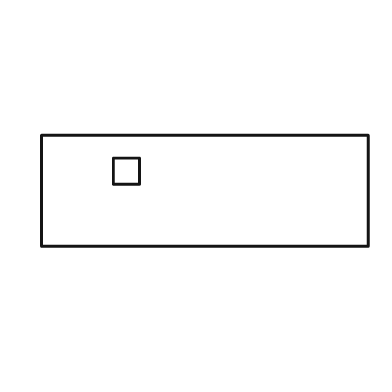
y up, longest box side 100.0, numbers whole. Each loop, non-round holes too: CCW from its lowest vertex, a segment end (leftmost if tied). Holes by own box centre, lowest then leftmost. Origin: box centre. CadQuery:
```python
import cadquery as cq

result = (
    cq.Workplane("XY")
    .moveTo(-50.0, -17.0)
    .lineTo(50.0, -17.0)
    .lineTo(50.0, 17.0)
    .lineTo(-50.0, 17.0)
    .close()
    .moveTo(-28.0, 2.0)
    .lineTo(-20.0, 2.0)
    .lineTo(-20.0, 10.0)
    .lineTo(-28.0, 10.0)
    .close()
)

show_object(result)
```